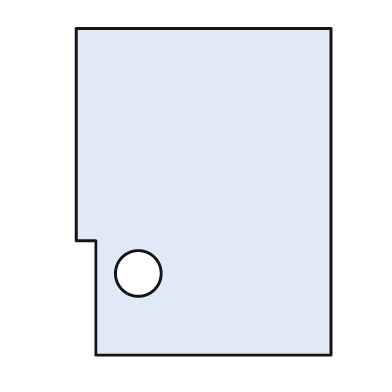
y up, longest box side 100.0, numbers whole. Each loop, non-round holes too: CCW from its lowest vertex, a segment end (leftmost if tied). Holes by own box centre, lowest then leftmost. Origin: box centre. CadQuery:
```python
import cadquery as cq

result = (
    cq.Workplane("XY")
    .moveTo(-33.0, -50.0)
    .lineTo(39.0, -50.0)
    .lineTo(39.0, 50.0)
    .lineTo(-39.0, 50.0)
    .lineTo(-39.0, -15.0)
    .lineTo(-33.0, -15.0)
    .close()
    .moveTo(-20.0, -25.0)
    .circle(7.0)
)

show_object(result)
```